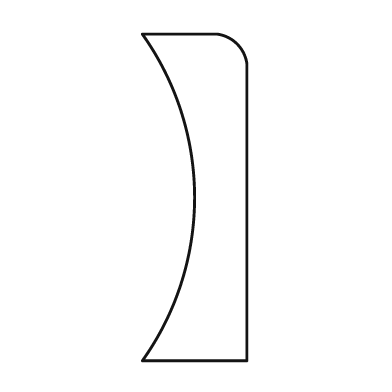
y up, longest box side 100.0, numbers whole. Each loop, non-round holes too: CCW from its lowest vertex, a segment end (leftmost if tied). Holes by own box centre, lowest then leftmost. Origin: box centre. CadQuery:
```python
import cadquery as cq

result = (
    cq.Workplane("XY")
    .moveTo(-16.0, -50.0)
    .lineTo(16.0, -50.0)
    .lineTo(16.0, 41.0)
    .threePointArc((13.0, 47.0), (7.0, 50.0))
    .lineTo(-16.0, 50.0)
    .threePointArc((0.0, 0.0), (-16.0, -50.0))
    .close()
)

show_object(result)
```